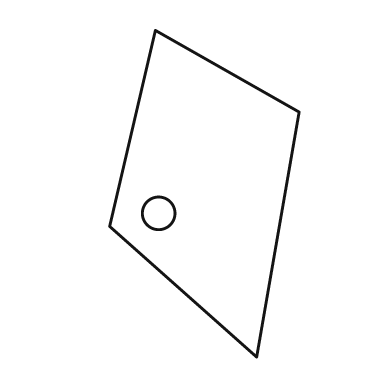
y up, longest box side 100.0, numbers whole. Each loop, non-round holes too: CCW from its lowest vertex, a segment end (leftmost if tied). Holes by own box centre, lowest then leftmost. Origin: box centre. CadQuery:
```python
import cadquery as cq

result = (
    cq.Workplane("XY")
    .moveTo(16.0, -50.0)
    .lineTo(29.0, 25.0)
    .lineTo(-15.0, 50.0)
    .lineTo(-29.0, -10.0)
    .close()
    .moveTo(-14.0, -6.0)
    .circle(5.0)
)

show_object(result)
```